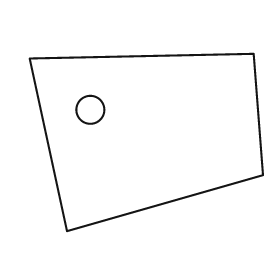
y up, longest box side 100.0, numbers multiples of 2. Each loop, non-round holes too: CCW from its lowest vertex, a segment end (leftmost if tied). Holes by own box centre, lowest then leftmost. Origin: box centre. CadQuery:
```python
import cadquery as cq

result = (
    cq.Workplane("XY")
    .moveTo(-34.0, -38.0)
    .lineTo(50.0, -14.0)
    .lineTo(46.0, 38.0)
    .lineTo(-50.0, 36.0)
    .close()
    .moveTo(-24.0, 14.0)
    .circle(6.0)
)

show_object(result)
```